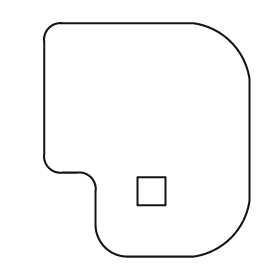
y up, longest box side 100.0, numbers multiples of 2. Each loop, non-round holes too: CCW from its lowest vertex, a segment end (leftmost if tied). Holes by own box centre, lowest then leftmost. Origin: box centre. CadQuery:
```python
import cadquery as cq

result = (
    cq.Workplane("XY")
    .moveTo(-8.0, -50.0)
    .lineTo(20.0, -50.0)
    .threePointArc((36.0, -42.0), (44.0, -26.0))
    .lineTo(44.0, 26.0)
    .threePointArc((36.0, 42.0), (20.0, 50.0))
    .lineTo(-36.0, 50.0)
    .threePointArc((-42.0, 48.0), (-44.0, 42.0))
    .lineTo(-44.0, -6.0)
    .threePointArc((-42.0, -12.0), (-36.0, -14.0))
    .lineTo(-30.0, -14.0)
    .threePointArc((-24.0, -16.0), (-22.0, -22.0))
    .lineTo(-22.0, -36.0)
    .threePointArc((-18.0, -46.0), (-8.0, -50.0))
    .close()
    .moveTo(-4.0, -28.0)
    .lineTo(8.0, -28.0)
    .lineTo(8.0, -16.0)
    .lineTo(-4.0, -16.0)
    .close()
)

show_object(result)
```